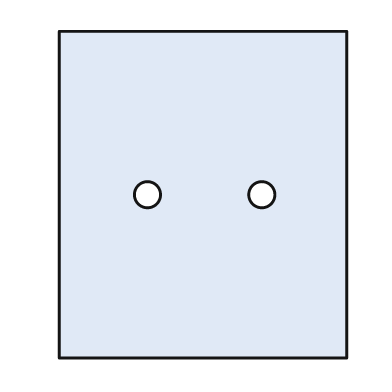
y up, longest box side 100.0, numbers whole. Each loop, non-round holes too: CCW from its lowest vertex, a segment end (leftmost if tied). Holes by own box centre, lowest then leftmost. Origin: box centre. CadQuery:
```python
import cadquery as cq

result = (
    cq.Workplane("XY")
    .moveTo(-44.0, -50.0)
    .lineTo(44.0, -50.0)
    .lineTo(44.0, 50.0)
    .lineTo(-44.0, 50.0)
    .close()
    .moveTo(-17.0, 0.0)
    .circle(4.0)
    .moveTo(18.0, 0.0)
    .circle(4.0)
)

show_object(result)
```